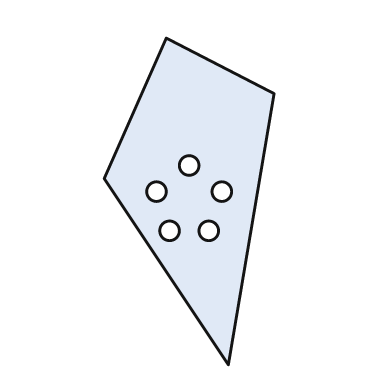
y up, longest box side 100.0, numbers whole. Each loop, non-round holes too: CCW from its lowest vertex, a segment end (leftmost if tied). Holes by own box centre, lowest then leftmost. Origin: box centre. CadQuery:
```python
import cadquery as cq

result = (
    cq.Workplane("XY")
    .moveTo(12.0, -50.0)
    .lineTo(26.0, 33.0)
    .lineTo(-7.0, 50.0)
    .lineTo(-26.0, 7.0)
    .close()
    .moveTo(-6.0, -9.0)
    .circle(3.0)
    .moveTo(6.0, -9.0)
    .circle(3.0)
    .moveTo(-10.0, 3.0)
    .circle(3.0)
    .moveTo(10.0, 3.0)
    .circle(3.0)
    .moveTo(0.0, 11.0)
    .circle(3.0)
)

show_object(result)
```